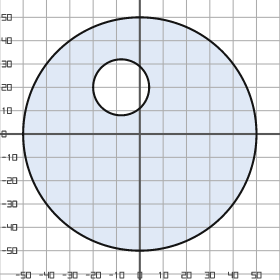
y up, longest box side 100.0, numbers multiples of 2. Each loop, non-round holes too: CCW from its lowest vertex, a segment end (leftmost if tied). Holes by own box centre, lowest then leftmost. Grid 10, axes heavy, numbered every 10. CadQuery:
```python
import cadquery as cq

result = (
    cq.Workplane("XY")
    .moveTo(0.0, 0.0)
    .circle(50.0)
    .moveTo(-8.0, 20.0)
    .circle(12.0)
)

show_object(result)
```